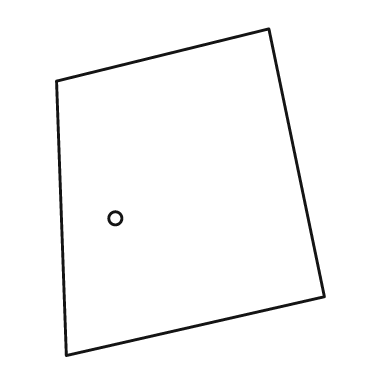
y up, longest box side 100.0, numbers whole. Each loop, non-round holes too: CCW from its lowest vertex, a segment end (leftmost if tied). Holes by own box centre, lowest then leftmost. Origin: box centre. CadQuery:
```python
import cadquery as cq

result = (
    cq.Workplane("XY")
    .moveTo(-38.0, -50.0)
    .lineTo(41.0, -32.0)
    .lineTo(24.0, 50.0)
    .lineTo(-41.0, 34.0)
    .close()
    .moveTo(-23.0, -8.0)
    .circle(2.0)
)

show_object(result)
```